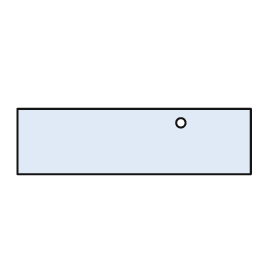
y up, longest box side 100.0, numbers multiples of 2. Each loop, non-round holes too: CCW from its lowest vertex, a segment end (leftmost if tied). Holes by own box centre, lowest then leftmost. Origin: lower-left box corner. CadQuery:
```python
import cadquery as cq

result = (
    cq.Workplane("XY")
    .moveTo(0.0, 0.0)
    .lineTo(100.0, 0.0)
    .lineTo(100.0, 28.0)
    .lineTo(0.0, 28.0)
    .close()
    .moveTo(70.0, 22.0)
    .circle(2.0)
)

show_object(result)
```